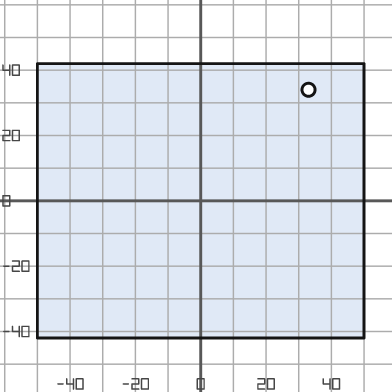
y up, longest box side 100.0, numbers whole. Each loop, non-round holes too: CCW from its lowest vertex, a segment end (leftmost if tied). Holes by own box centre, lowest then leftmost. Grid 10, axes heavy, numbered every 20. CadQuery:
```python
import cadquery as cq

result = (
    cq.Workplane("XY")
    .moveTo(-50.0, -42.0)
    .lineTo(50.0, -42.0)
    .lineTo(50.0, 42.0)
    .lineTo(-50.0, 42.0)
    .close()
    .moveTo(33.0, 34.0)
    .circle(2.0)
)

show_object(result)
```